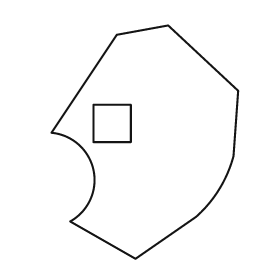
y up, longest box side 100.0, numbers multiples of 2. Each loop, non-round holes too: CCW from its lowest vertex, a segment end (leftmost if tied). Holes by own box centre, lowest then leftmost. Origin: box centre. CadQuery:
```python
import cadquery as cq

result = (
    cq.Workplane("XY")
    .moveTo(-4.0, -50.0)
    .lineTo(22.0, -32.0)
    .threePointArc((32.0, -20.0), (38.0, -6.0))
    .lineTo(40.0, 22.0)
    .lineTo(10.0, 50.0)
    .lineTo(-12.0, 46.0)
    .lineTo(-40.0, 4.0)
    .threePointArc((-22.0, -12.0), (-32.0, -34.0))
    .close()
    .moveTo(-22.0, 0.0)
    .lineTo(-6.0, 0.0)
    .lineTo(-6.0, 16.0)
    .lineTo(-22.0, 16.0)
    .close()
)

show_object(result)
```